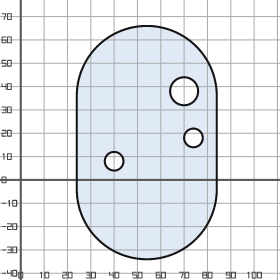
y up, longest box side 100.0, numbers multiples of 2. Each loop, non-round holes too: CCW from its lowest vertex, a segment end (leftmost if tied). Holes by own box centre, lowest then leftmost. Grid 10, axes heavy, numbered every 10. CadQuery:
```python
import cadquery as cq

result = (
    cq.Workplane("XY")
    .moveTo(24.0, -4.0)
    .threePointArc((54.0, -34.0), (84.0, -4.0))
    .lineTo(84.0, 36.0)
    .threePointArc((54.0, 66.0), (24.0, 36.0))
    .close()
    .moveTo(40.0, 8.0)
    .circle(4.0)
    .moveTo(74.0, 18.0)
    .circle(4.0)
    .moveTo(70.0, 38.0)
    .circle(6.0)
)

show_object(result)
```